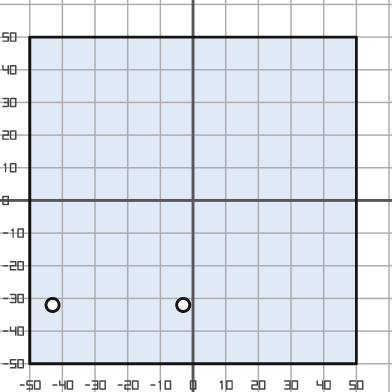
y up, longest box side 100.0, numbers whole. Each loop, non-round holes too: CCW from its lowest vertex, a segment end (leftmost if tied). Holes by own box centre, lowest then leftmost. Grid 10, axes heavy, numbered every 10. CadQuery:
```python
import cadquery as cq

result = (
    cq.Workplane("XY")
    .moveTo(-50.0, -50.0)
    .lineTo(50.0, -50.0)
    .lineTo(50.0, 50.0)
    .lineTo(-50.0, 50.0)
    .close()
    .moveTo(-43.0, -32.0)
    .circle(2.0)
    .moveTo(-3.0, -32.0)
    .circle(2.0)
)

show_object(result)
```